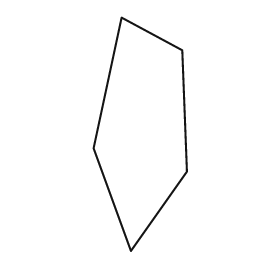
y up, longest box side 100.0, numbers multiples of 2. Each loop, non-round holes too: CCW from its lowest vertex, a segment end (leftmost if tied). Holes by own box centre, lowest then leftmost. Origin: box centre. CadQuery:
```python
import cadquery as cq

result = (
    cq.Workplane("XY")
    .moveTo(-4.0, -50.0)
    .lineTo(20.0, -16.0)
    .lineTo(18.0, 36.0)
    .lineTo(-8.0, 50.0)
    .lineTo(-20.0, -6.0)
    .close()
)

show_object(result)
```